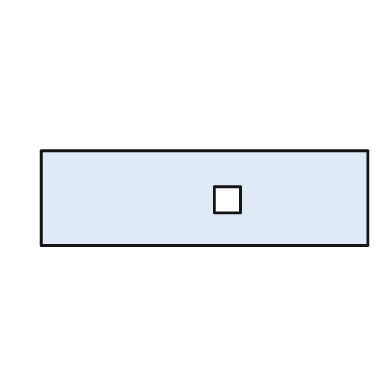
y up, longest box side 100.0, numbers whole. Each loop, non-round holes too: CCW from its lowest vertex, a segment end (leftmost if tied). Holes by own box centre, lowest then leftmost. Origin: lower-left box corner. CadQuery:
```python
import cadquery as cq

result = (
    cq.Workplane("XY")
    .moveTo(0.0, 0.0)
    .lineTo(100.0, 0.0)
    .lineTo(100.0, 29.0)
    .lineTo(0.0, 29.0)
    .close()
    .moveTo(53.0, 10.0)
    .lineTo(61.0, 10.0)
    .lineTo(61.0, 18.0)
    .lineTo(53.0, 18.0)
    .close()
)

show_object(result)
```